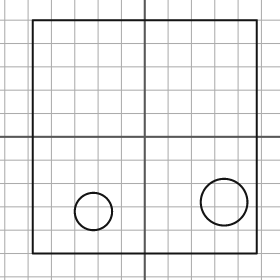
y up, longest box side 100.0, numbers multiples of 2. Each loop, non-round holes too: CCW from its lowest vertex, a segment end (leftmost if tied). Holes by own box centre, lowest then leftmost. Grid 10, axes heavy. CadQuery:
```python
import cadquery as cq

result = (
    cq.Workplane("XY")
    .moveTo(-48.0, -50.0)
    .lineTo(48.0, -50.0)
    .lineTo(48.0, 50.0)
    .lineTo(-48.0, 50.0)
    .close()
    .moveTo(-22.0, -32.0)
    .circle(8.0)
    .moveTo(34.0, -28.0)
    .circle(10.0)
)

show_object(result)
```